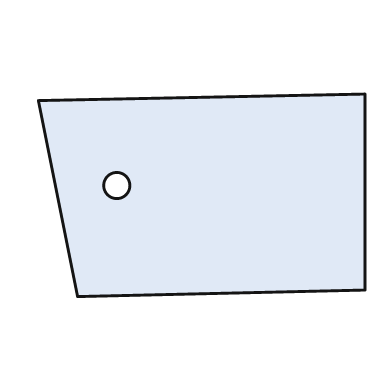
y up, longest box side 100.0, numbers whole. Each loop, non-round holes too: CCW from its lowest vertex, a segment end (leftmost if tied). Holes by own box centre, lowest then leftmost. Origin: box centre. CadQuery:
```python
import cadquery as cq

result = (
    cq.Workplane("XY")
    .moveTo(-38.0, -31.0)
    .lineTo(50.0, -29.0)
    .lineTo(50.0, 31.0)
    .lineTo(-50.0, 29.0)
    .close()
    .moveTo(-26.0, 3.0)
    .circle(4.0)
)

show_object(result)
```